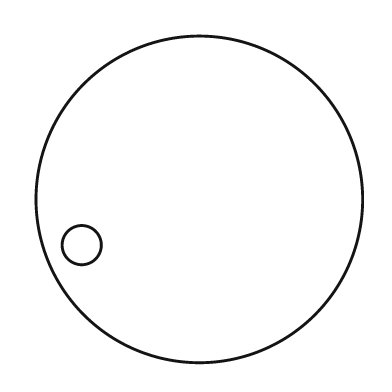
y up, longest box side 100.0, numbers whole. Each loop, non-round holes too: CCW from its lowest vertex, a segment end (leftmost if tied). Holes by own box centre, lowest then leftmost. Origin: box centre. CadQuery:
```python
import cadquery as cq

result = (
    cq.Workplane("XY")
    .moveTo(0.0, 0.0)
    .circle(50.0)
    .moveTo(-36.0, -14.0)
    .circle(6.0)
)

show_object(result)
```